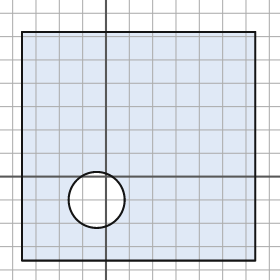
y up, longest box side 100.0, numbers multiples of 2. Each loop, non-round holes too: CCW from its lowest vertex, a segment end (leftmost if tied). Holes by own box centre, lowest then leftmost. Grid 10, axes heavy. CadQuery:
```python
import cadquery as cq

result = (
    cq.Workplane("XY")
    .moveTo(-36.0, -36.0)
    .lineTo(64.0, -36.0)
    .lineTo(64.0, 62.0)
    .lineTo(-36.0, 62.0)
    .close()
    .moveTo(-4.0, -10.0)
    .circle(12.0)
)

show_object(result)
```